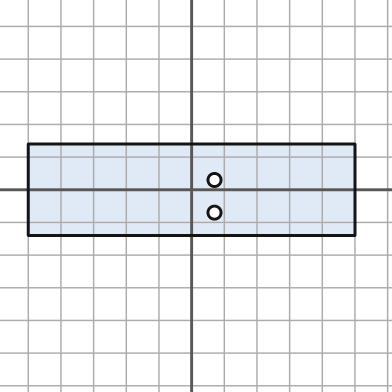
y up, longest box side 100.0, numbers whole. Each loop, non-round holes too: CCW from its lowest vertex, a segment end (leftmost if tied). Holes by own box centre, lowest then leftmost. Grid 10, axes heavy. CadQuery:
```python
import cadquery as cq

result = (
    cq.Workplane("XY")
    .moveTo(-50.0, -14.0)
    .lineTo(50.0, -14.0)
    .lineTo(50.0, 14.0)
    .lineTo(-50.0, 14.0)
    .close()
    .moveTo(7.0, -7.0)
    .circle(2.0)
    .moveTo(7.0, 3.0)
    .circle(2.0)
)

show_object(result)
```